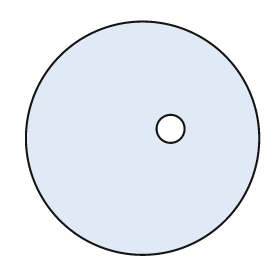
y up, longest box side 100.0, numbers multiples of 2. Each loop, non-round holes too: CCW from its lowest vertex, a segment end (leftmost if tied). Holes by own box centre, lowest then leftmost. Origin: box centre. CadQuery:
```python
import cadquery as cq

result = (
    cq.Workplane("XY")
    .moveTo(0.0, 0.0)
    .circle(50.0)
    .moveTo(12.0, 4.0)
    .circle(6.0)
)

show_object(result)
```